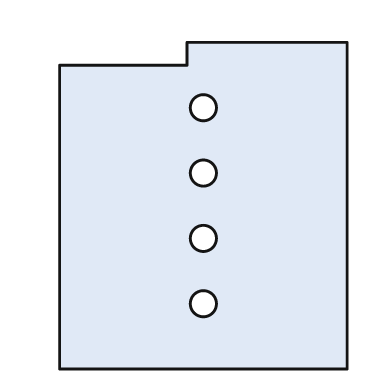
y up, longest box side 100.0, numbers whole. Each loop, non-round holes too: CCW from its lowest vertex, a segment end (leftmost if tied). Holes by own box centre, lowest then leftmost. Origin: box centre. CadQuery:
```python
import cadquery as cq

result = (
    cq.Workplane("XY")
    .moveTo(-44.0, -50.0)
    .lineTo(44.0, -50.0)
    .lineTo(44.0, 50.0)
    .lineTo(-5.0, 50.0)
    .lineTo(-5.0, 43.0)
    .lineTo(-44.0, 43.0)
    .close()
    .moveTo(0.0, -30.0)
    .circle(4.0)
    .moveTo(0.0, -10.0)
    .circle(4.0)
    .moveTo(0.0, 10.0)
    .circle(4.0)
    .moveTo(0.0, 30.0)
    .circle(4.0)
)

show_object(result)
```